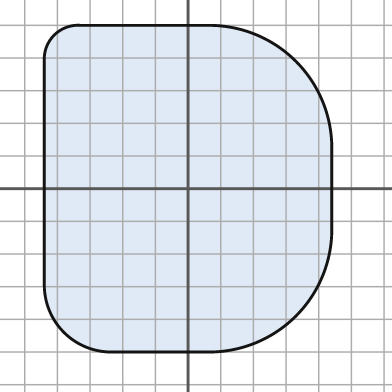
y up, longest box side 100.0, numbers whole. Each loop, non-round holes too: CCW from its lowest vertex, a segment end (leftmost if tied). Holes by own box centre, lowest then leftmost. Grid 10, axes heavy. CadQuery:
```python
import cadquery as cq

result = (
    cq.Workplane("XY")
    .moveTo(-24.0, -50.0)
    .lineTo(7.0, -50.0)
    .threePointArc((33.0, -39.0), (44.0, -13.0))
    .lineTo(44.0, 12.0)
    .threePointArc((33.0, 39.0), (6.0, 50.0))
    .lineTo(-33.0, 50.0)
    .threePointArc((-41.0, 47.0), (-44.0, 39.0))
    .lineTo(-44.0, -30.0)
    .threePointArc((-38.0, -44.0), (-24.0, -50.0))
    .close()
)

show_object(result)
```